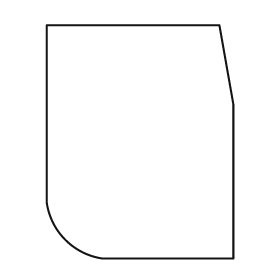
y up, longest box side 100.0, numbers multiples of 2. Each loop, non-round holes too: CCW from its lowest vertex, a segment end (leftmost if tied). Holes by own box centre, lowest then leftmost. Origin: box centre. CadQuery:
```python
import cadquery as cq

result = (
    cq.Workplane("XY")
    .moveTo(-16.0, -50.0)
    .lineTo(40.0, -50.0)
    .lineTo(40.0, 16.0)
    .lineTo(34.0, 50.0)
    .lineTo(-40.0, 50.0)
    .lineTo(-40.0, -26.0)
    .threePointArc((-32.0, -42.0), (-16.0, -50.0))
    .close()
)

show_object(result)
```